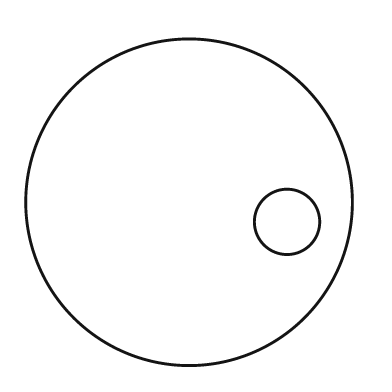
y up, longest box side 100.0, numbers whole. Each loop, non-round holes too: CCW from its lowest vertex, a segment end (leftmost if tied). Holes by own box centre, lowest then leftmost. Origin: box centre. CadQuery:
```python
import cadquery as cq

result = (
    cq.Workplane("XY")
    .moveTo(0.0, 0.0)
    .circle(50.0)
    .moveTo(30.0, -6.0)
    .circle(10.0)
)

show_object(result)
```